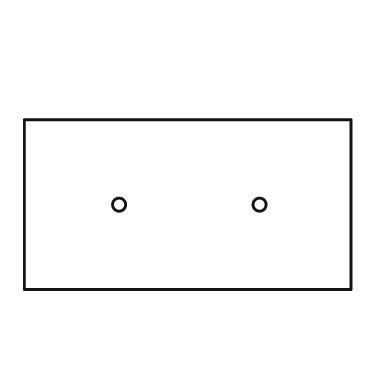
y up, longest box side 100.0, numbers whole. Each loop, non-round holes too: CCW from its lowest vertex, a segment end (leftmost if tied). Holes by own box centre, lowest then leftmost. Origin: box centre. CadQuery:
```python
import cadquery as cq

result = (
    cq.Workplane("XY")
    .moveTo(-50.0, -26.0)
    .lineTo(50.0, -26.0)
    .lineTo(50.0, 26.0)
    .lineTo(-50.0, 26.0)
    .close()
    .moveTo(-21.0, 0.0)
    .circle(2.0)
    .moveTo(22.0, 0.0)
    .circle(2.0)
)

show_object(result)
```